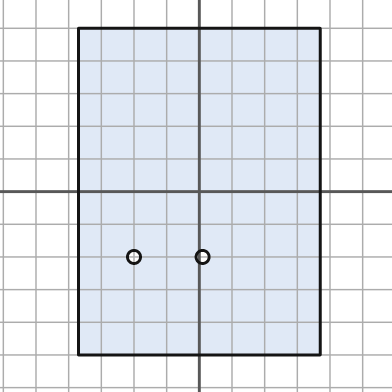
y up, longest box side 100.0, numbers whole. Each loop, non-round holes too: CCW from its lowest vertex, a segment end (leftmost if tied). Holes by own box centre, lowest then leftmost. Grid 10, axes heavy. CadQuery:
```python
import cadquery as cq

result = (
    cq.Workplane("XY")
    .moveTo(-37.0, -50.0)
    .lineTo(37.0, -50.0)
    .lineTo(37.0, 50.0)
    .lineTo(-37.0, 50.0)
    .close()
    .moveTo(-20.0, -20.0)
    .circle(2.0)
    .moveTo(1.0, -20.0)
    .circle(2.0)
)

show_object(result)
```